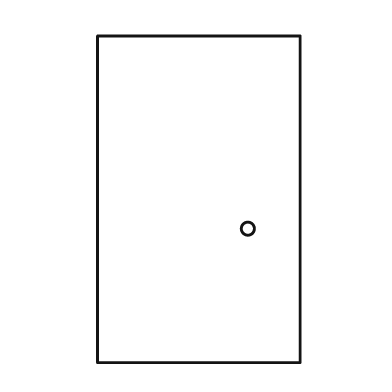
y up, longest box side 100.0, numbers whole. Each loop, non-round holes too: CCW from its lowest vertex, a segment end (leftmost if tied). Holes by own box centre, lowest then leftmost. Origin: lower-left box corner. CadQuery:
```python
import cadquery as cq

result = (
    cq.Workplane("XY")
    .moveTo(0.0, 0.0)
    .lineTo(62.0, 0.0)
    .lineTo(62.0, 100.0)
    .lineTo(0.0, 100.0)
    .close()
    .moveTo(46.0, 41.0)
    .circle(2.0)
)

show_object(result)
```